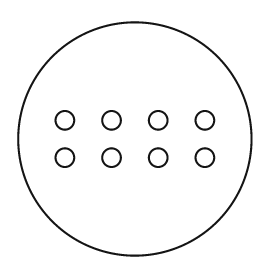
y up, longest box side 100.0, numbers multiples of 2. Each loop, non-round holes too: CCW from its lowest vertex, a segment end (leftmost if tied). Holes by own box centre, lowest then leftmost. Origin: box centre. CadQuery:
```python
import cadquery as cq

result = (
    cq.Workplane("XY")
    .moveTo(0.0, 0.0)
    .circle(50.0)
    .moveTo(-30.0, -8.0)
    .circle(4.0)
    .moveTo(-10.0, -8.0)
    .circle(4.0)
    .moveTo(10.0, -8.0)
    .circle(4.0)
    .moveTo(30.0, -8.0)
    .circle(4.0)
    .moveTo(-30.0, 8.0)
    .circle(4.0)
    .moveTo(-10.0, 8.0)
    .circle(4.0)
    .moveTo(10.0, 8.0)
    .circle(4.0)
    .moveTo(30.0, 8.0)
    .circle(4.0)
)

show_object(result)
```